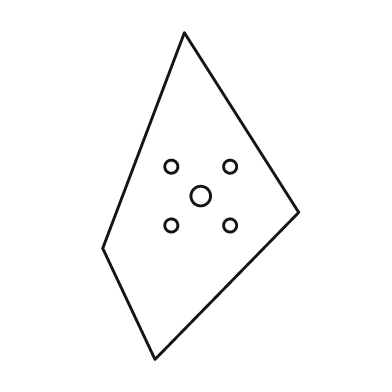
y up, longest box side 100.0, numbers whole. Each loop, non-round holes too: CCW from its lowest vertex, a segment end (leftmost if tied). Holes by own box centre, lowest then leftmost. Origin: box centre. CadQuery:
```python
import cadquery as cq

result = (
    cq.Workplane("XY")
    .moveTo(-14.0, -50.0)
    .lineTo(30.0, -5.0)
    .lineTo(-5.0, 50.0)
    .lineTo(-30.0, -16.0)
    .close()
    .moveTo(-9.0, -9.0)
    .circle(2.0)
    .moveTo(9.0, -9.0)
    .circle(2.0)
    .moveTo(0.0, 0.0)
    .circle(3.0)
    .moveTo(-9.0, 9.0)
    .circle(2.0)
    .moveTo(9.0, 9.0)
    .circle(2.0)
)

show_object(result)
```